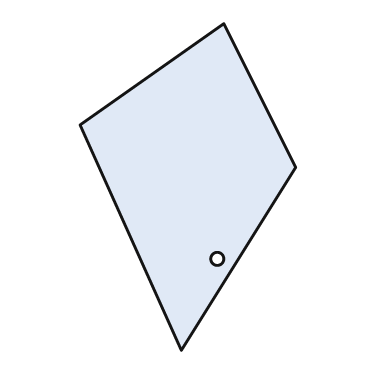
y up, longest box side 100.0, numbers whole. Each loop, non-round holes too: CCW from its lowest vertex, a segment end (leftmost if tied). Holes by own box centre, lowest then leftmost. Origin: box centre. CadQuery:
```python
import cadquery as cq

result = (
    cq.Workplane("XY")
    .moveTo(-2.0, -50.0)
    .lineTo(33.0, 6.0)
    .lineTo(11.0, 50.0)
    .lineTo(-33.0, 19.0)
    .close()
    .moveTo(9.0, -22.0)
    .circle(2.0)
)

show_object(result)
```